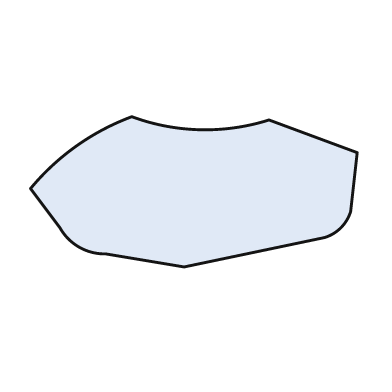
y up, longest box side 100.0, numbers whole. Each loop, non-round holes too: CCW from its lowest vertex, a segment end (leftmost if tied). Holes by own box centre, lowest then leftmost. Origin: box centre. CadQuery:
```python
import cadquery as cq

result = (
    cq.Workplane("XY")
    .moveTo(-3.0, -23.0)
    .lineTo(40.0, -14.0)
    .threePointArc((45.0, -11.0), (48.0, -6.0))
    .lineTo(50.0, 12.0)
    .lineTo(23.0, 22.0)
    .threePointArc((2.0, 19.0), (-19.0, 23.0))
    .threePointArc((-36.0, 14.0), (-50.0, 1.0))
    .lineTo(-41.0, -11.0)
    .threePointArc((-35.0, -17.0), (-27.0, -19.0))
    .close()
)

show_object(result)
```